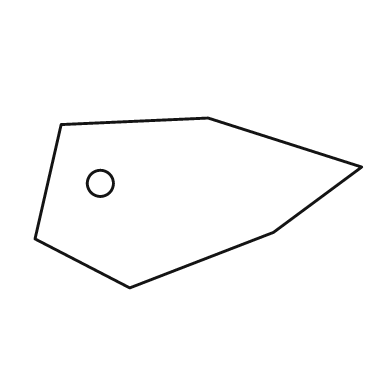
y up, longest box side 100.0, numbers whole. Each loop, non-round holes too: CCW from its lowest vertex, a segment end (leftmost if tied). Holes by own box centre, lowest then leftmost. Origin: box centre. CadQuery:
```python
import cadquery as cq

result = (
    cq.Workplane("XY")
    .moveTo(-21.0, -26.0)
    .lineTo(23.0, -9.0)
    .lineTo(50.0, 11.0)
    .lineTo(3.0, 26.0)
    .lineTo(-42.0, 24.0)
    .lineTo(-50.0, -11.0)
    .close()
    .moveTo(-30.0, 6.0)
    .circle(4.0)
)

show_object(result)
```